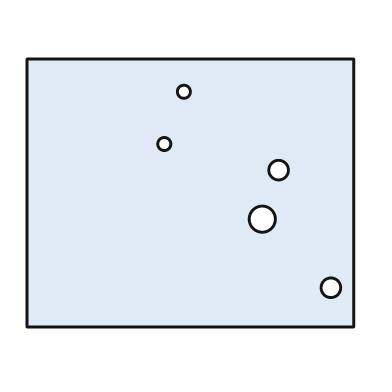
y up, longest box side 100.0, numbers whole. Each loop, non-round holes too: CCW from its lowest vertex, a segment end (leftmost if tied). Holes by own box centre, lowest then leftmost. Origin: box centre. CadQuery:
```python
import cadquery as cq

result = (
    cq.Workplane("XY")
    .moveTo(-50.0, -41.0)
    .lineTo(50.0, -41.0)
    .lineTo(50.0, 41.0)
    .lineTo(-50.0, 41.0)
    .close()
    .moveTo(43.0, -29.0)
    .circle(3.0)
    .moveTo(22.0, -8.0)
    .circle(4.0)
    .moveTo(27.0, 7.0)
    .circle(3.0)
    .moveTo(-8.0, 15.0)
    .circle(2.0)
    .moveTo(-2.0, 31.0)
    .circle(2.0)
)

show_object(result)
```